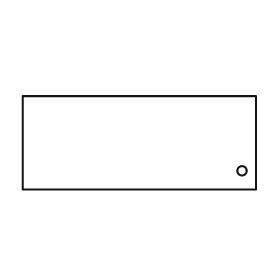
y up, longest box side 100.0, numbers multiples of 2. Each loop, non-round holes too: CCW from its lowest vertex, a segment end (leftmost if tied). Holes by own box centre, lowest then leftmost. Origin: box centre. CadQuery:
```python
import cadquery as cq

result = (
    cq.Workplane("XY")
    .moveTo(-50.0, -20.0)
    .lineTo(50.0, -20.0)
    .lineTo(50.0, 20.0)
    .lineTo(-50.0, 20.0)
    .close()
    .moveTo(44.0, -12.0)
    .circle(2.0)
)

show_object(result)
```